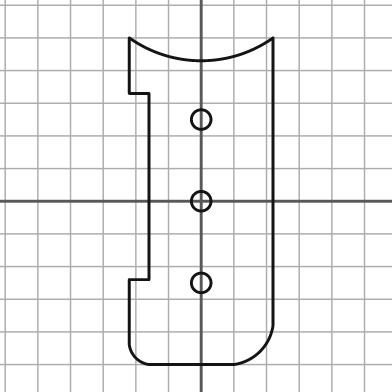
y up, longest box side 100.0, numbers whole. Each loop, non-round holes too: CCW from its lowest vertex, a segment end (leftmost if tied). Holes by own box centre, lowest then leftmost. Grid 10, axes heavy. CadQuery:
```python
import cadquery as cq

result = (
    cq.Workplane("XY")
    .moveTo(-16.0, -50.0)
    .lineTo(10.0, -50.0)
    .threePointArc((18.0, -46.0), (22.0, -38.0))
    .lineTo(22.0, 50.0)
    .threePointArc((0.0, 43.0), (-22.0, 50.0))
    .lineTo(-22.0, 33.0)
    .lineTo(-16.0, 33.0)
    .lineTo(-16.0, -24.0)
    .lineTo(-22.0, -24.0)
    .lineTo(-22.0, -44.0)
    .threePointArc((-20.0, -48.0), (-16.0, -50.0))
    .close()
    .moveTo(0.0, -25.0)
    .circle(3.0)
    .moveTo(0.0, 0.0)
    .circle(3.0)
    .moveTo(0.0, 25.0)
    .circle(3.0)
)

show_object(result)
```